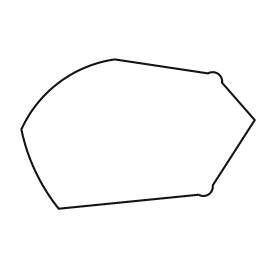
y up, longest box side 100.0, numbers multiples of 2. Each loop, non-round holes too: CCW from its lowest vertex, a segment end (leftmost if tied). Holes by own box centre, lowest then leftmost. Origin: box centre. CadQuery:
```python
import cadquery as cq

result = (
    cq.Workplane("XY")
    .moveTo(-34.0, -32.0)
    .lineTo(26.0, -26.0)
    .threePointArc((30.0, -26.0), (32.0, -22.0))
    .lineTo(50.0, 6.0)
    .lineTo(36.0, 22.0)
    .threePointArc((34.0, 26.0), (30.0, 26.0))
    .lineTo(-10.0, 32.0)
    .threePointArc((-34.0, 22.0), (-50.0, 2.0))
    .threePointArc((-44.0, -16.0), (-34.0, -32.0))
    .close()
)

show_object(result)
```